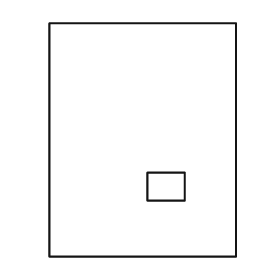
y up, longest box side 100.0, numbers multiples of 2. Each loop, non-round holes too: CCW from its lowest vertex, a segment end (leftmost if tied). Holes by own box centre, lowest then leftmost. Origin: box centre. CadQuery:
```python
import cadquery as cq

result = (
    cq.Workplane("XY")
    .moveTo(-40.0, -50.0)
    .lineTo(40.0, -50.0)
    .lineTo(40.0, 50.0)
    .lineTo(-40.0, 50.0)
    .close()
    .moveTo(2.0, -26.0)
    .lineTo(18.0, -26.0)
    .lineTo(18.0, -14.0)
    .lineTo(2.0, -14.0)
    .close()
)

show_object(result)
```